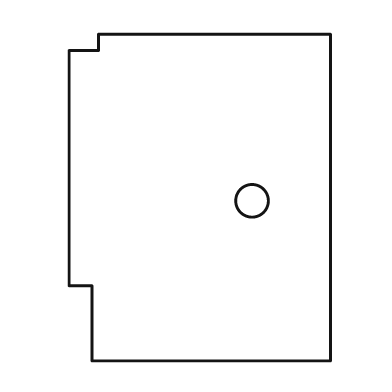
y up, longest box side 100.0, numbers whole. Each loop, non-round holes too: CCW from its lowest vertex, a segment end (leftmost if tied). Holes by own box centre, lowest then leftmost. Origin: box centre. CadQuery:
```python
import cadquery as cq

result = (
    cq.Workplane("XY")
    .moveTo(-33.0, -50.0)
    .lineTo(40.0, -50.0)
    .lineTo(40.0, 50.0)
    .lineTo(-31.0, 50.0)
    .lineTo(-31.0, 45.0)
    .lineTo(-40.0, 45.0)
    .lineTo(-40.0, -27.0)
    .lineTo(-33.0, -27.0)
    .close()
    .moveTo(16.0, -1.0)
    .circle(5.0)
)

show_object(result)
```